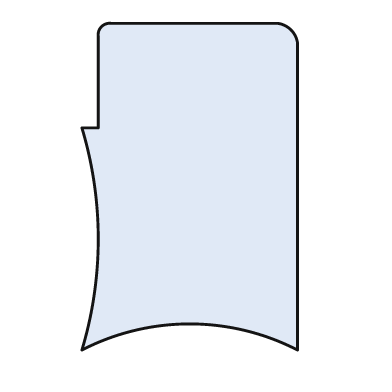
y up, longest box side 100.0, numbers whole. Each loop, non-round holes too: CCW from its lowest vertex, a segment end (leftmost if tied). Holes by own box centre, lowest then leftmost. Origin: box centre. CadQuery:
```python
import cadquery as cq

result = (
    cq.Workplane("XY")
    .moveTo(-33.0, -50.0)
    .threePointArc((0.0, -42.0), (33.0, -50.0))
    .lineTo(33.0, 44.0)
    .threePointArc((31.0, 48.0), (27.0, 50.0))
    .lineTo(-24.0, 50.0)
    .threePointArc((-27.0, 49.0), (-28.0, 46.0))
    .lineTo(-28.0, 18.0)
    .lineTo(-33.0, 18.0)
    .threePointArc((-28.0, -16.0), (-33.0, -50.0))
    .close()
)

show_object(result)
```